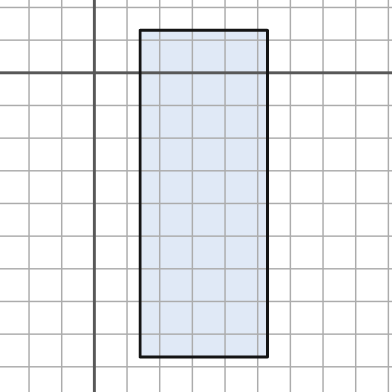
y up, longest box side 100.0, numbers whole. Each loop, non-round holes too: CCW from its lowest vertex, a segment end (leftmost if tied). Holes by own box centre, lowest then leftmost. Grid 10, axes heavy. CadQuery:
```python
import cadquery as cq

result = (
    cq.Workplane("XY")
    .moveTo(14.0, -87.0)
    .lineTo(53.0, -87.0)
    .lineTo(53.0, 13.0)
    .lineTo(14.0, 13.0)
    .close()
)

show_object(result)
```